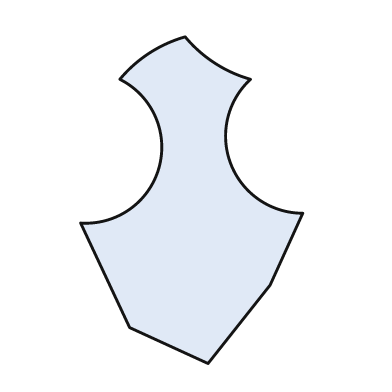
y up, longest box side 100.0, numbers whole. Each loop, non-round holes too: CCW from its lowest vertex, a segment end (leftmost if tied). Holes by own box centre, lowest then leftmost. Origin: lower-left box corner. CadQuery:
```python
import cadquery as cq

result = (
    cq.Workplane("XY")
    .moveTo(39.0, 0.0)
    .lineTo(58.0, 24.0)
    .lineTo(68.0, 46.0)
    .threePointArc((46.0, 61.0), (52.0, 87.0))
    .threePointArc((41.0, 92.0), (32.0, 100.0))
    .threePointArc((21.0, 95.0), (12.0, 87.0))
    .threePointArc((24.0, 60.0), (0.0, 43.0))
    .lineTo(15.0, 11.0)
    .close()
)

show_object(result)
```